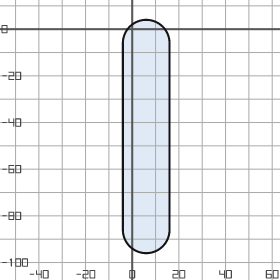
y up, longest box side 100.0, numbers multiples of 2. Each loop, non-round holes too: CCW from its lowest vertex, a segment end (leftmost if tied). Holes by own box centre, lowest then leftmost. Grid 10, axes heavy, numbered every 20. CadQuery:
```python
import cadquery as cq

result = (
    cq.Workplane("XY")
    .moveTo(-4.0, -86.0)
    .threePointArc((6.0, -96.0), (16.0, -86.0))
    .lineTo(16.0, -6.0)
    .threePointArc((6.0, 4.0), (-4.0, -6.0))
    .close()
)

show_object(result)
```